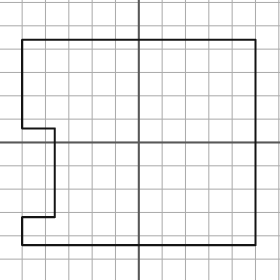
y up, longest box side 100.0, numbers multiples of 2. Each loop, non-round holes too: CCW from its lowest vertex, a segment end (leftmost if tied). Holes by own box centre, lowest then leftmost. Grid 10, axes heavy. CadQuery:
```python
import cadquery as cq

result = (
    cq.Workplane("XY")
    .moveTo(-50.0, -44.0)
    .lineTo(50.0, -44.0)
    .lineTo(50.0, 44.0)
    .lineTo(-50.0, 44.0)
    .lineTo(-50.0, 6.0)
    .lineTo(-36.0, 6.0)
    .lineTo(-36.0, -32.0)
    .lineTo(-50.0, -32.0)
    .close()
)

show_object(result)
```